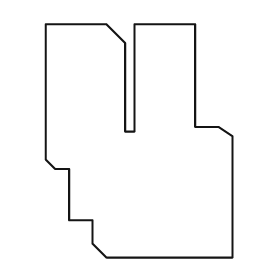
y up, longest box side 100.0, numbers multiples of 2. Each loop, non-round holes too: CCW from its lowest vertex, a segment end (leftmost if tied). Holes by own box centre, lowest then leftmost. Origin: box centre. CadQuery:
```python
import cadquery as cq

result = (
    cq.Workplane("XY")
    .moveTo(-14.0, -50.0)
    .lineTo(40.0, -50.0)
    .lineTo(40.0, 2.0)
    .lineTo(34.0, 6.0)
    .lineTo(24.0, 6.0)
    .lineTo(24.0, 50.0)
    .lineTo(-2.0, 50.0)
    .lineTo(-2.0, 4.0)
    .lineTo(-6.0, 4.0)
    .lineTo(-6.0, 42.0)
    .lineTo(-14.0, 50.0)
    .lineTo(-40.0, 50.0)
    .lineTo(-40.0, -8.0)
    .lineTo(-36.0, -12.0)
    .lineTo(-30.0, -12.0)
    .lineTo(-30.0, -34.0)
    .lineTo(-20.0, -34.0)
    .lineTo(-20.0, -44.0)
    .close()
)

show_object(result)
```